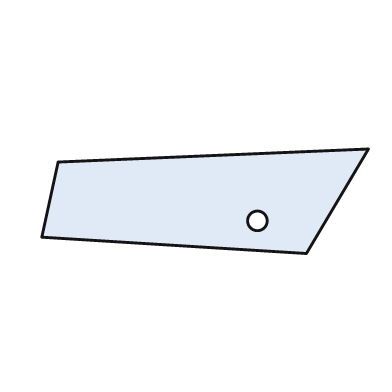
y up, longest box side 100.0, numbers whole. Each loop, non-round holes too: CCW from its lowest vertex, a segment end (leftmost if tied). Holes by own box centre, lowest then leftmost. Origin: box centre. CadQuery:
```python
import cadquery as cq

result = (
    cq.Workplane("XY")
    .moveTo(31.0, -16.0)
    .lineTo(50.0, 16.0)
    .lineTo(-45.0, 12.0)
    .lineTo(-50.0, -11.0)
    .close()
    .moveTo(16.0, -6.0)
    .circle(3.0)
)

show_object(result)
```